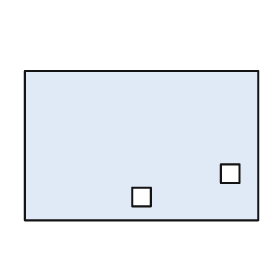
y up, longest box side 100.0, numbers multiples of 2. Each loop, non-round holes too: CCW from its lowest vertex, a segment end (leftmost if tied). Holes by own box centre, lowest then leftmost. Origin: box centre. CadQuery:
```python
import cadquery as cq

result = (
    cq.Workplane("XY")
    .moveTo(-50.0, -32.0)
    .lineTo(50.0, -32.0)
    .lineTo(50.0, 32.0)
    .lineTo(-50.0, 32.0)
    .close()
    .moveTo(-4.0, -26.0)
    .lineTo(4.0, -26.0)
    .lineTo(4.0, -18.0)
    .lineTo(-4.0, -18.0)
    .close()
    .moveTo(34.0, -16.0)
    .lineTo(42.0, -16.0)
    .lineTo(42.0, -8.0)
    .lineTo(34.0, -8.0)
    .close()
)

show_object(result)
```